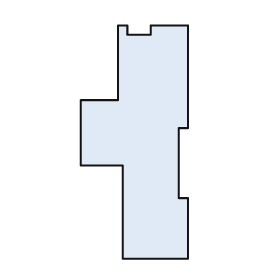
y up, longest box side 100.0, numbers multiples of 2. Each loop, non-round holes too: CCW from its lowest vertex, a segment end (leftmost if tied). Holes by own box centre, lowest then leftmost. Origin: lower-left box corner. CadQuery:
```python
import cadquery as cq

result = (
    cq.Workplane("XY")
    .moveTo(18.0, 0.0)
    .lineTo(46.0, 0.0)
    .lineTo(46.0, 26.0)
    .lineTo(42.0, 26.0)
    .lineTo(42.0, 56.0)
    .lineTo(46.0, 56.0)
    .lineTo(46.0, 100.0)
    .lineTo(30.0, 100.0)
    .lineTo(30.0, 96.0)
    .lineTo(20.0, 96.0)
    .lineTo(20.0, 100.0)
    .lineTo(16.0, 100.0)
    .lineTo(16.0, 68.0)
    .lineTo(0.0, 68.0)
    .lineTo(0.0, 40.0)
    .lineTo(18.0, 40.0)
    .close()
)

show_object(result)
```